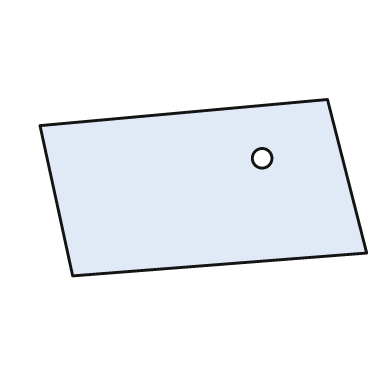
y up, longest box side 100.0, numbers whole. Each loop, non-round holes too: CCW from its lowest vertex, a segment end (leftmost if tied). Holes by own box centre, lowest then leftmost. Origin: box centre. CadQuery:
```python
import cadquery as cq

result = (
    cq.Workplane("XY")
    .moveTo(-40.0, -27.0)
    .lineTo(50.0, -20.0)
    .lineTo(38.0, 27.0)
    .lineTo(-50.0, 19.0)
    .close()
    .moveTo(18.0, 9.0)
    .circle(3.0)
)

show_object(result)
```